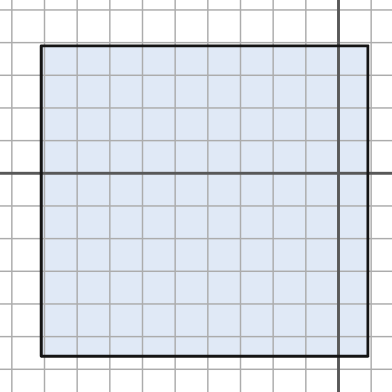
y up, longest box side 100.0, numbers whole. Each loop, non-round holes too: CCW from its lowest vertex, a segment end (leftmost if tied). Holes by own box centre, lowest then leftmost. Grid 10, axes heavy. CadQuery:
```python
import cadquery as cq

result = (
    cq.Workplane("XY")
    .moveTo(-91.0, -56.0)
    .lineTo(9.0, -56.0)
    .lineTo(9.0, 39.0)
    .lineTo(-91.0, 39.0)
    .close()
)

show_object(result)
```